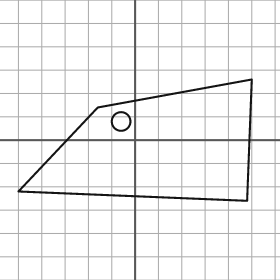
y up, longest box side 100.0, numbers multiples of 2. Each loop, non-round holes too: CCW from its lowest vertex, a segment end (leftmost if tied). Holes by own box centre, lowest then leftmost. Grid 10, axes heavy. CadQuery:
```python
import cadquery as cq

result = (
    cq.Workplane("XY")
    .moveTo(48.0, -26.0)
    .lineTo(50.0, 26.0)
    .lineTo(-16.0, 14.0)
    .lineTo(-50.0, -22.0)
    .close()
    .moveTo(-6.0, 8.0)
    .circle(4.0)
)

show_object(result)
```